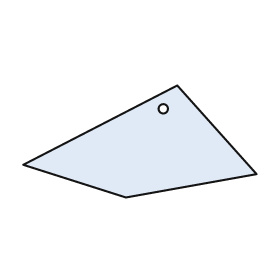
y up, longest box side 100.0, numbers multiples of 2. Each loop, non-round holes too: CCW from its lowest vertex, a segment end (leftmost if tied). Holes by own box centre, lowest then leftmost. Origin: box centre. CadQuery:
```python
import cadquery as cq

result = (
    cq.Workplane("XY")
    .moveTo(-6.0, -24.0)
    .lineTo(50.0, -14.0)
    .lineTo(16.0, 24.0)
    .lineTo(-50.0, -10.0)
    .close()
    .moveTo(10.0, 14.0)
    .circle(2.0)
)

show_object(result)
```